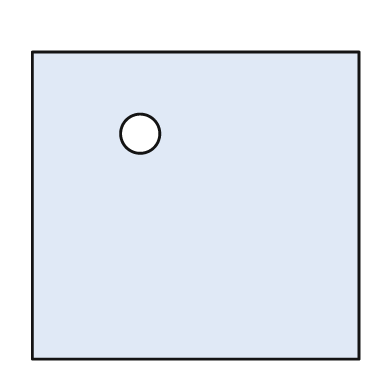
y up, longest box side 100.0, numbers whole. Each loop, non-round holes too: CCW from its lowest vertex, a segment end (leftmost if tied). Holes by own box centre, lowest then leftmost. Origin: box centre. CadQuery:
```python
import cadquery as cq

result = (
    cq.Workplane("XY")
    .moveTo(-50.0, -47.0)
    .lineTo(50.0, -47.0)
    .lineTo(50.0, 47.0)
    .lineTo(-50.0, 47.0)
    .close()
    .moveTo(-17.0, 22.0)
    .circle(6.0)
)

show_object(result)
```